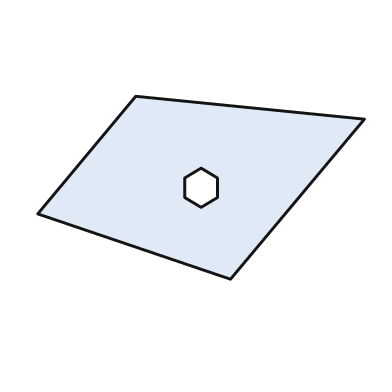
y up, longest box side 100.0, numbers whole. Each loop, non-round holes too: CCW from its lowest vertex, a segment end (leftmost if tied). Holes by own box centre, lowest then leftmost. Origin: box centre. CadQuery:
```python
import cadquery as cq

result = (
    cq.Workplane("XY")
    .moveTo(9.0, -28.0)
    .lineTo(50.0, 21.0)
    .lineTo(-20.0, 28.0)
    .lineTo(-50.0, -8.0)
    .close()
    .moveTo(0.0, -6.0)
    .lineTo(5.0, -3.0)
    .lineTo(5.0, 3.0)
    .lineTo(0.0, 6.0)
    .lineTo(-5.0, 3.0)
    .lineTo(-5.0, -3.0)
    .close()
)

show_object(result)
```